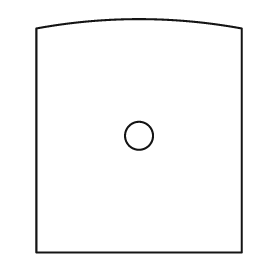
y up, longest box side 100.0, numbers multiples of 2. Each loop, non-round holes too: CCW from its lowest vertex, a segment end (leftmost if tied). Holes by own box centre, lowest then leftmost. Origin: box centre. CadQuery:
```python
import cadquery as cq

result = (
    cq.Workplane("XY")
    .moveTo(-44.0, -50.0)
    .lineTo(44.0, -50.0)
    .lineTo(44.0, 46.0)
    .threePointArc((0.0, 50.0), (-44.0, 46.0))
    .close()
    .moveTo(0.0, 0.0)
    .circle(6.0)
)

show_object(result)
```